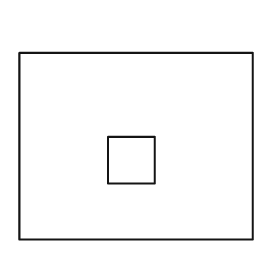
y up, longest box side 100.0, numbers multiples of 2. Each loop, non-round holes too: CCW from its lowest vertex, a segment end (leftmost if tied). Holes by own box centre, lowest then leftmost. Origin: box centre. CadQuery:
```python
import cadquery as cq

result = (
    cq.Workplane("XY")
    .moveTo(-50.0, -40.0)
    .lineTo(50.0, -40.0)
    .lineTo(50.0, 40.0)
    .lineTo(-50.0, 40.0)
    .close()
    .moveTo(-12.0, -16.0)
    .lineTo(8.0, -16.0)
    .lineTo(8.0, 4.0)
    .lineTo(-12.0, 4.0)
    .close()
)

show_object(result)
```